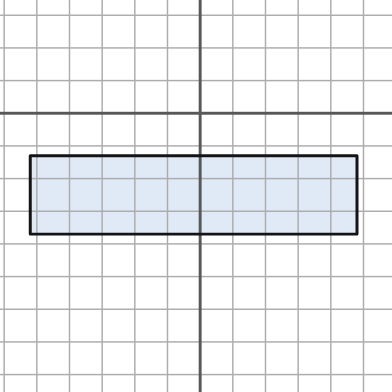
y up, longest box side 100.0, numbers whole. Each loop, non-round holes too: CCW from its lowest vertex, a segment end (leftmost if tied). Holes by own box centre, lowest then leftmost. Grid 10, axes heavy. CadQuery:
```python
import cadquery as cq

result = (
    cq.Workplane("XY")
    .moveTo(-52.0, -37.0)
    .lineTo(48.0, -37.0)
    .lineTo(48.0, -13.0)
    .lineTo(-52.0, -13.0)
    .close()
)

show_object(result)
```